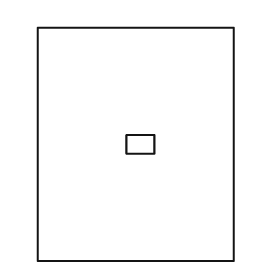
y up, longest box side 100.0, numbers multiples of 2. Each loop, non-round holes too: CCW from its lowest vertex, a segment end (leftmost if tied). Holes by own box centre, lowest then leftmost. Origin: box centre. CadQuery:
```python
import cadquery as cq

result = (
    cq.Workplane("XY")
    .moveTo(-42.0, -50.0)
    .lineTo(42.0, -50.0)
    .lineTo(42.0, 50.0)
    .lineTo(-42.0, 50.0)
    .close()
    .moveTo(-4.0, -4.0)
    .lineTo(8.0, -4.0)
    .lineTo(8.0, 4.0)
    .lineTo(-4.0, 4.0)
    .close()
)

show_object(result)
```